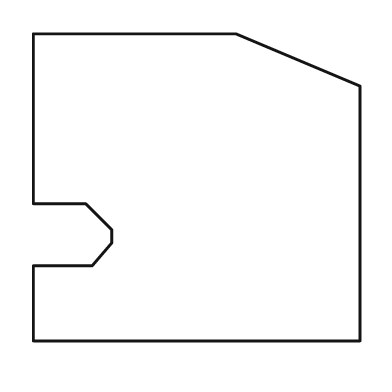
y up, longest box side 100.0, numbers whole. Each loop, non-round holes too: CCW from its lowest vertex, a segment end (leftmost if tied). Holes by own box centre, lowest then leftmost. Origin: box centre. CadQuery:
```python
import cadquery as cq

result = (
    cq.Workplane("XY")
    .moveTo(-50.0, -47.0)
    .lineTo(50.0, -47.0)
    .lineTo(50.0, 31.0)
    .lineTo(12.0, 47.0)
    .lineTo(-50.0, 47.0)
    .lineTo(-50.0, -5.0)
    .lineTo(-34.0, -5.0)
    .lineTo(-26.0, -13.0)
    .lineTo(-26.0, -17.0)
    .lineTo(-32.0, -24.0)
    .lineTo(-50.0, -24.0)
    .close()
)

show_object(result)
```